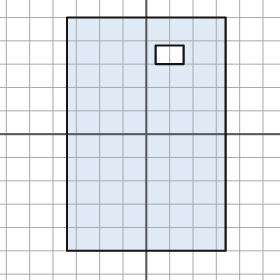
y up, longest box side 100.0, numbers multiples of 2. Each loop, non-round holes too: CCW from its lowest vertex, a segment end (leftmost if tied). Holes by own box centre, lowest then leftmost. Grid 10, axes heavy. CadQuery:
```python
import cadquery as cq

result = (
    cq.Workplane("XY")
    .moveTo(-34.0, -50.0)
    .lineTo(34.0, -50.0)
    .lineTo(34.0, 50.0)
    .lineTo(-34.0, 50.0)
    .close()
    .moveTo(4.0, 30.0)
    .lineTo(16.0, 30.0)
    .lineTo(16.0, 38.0)
    .lineTo(4.0, 38.0)
    .close()
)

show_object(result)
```